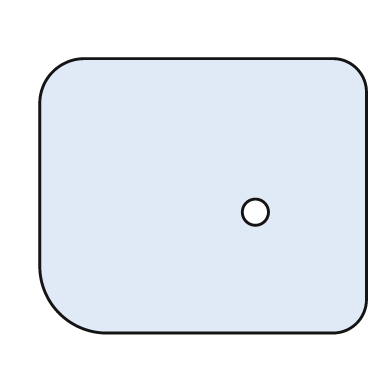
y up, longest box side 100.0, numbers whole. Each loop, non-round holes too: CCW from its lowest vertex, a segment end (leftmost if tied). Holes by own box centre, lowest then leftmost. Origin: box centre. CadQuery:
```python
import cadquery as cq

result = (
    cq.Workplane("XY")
    .moveTo(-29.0, -42.0)
    .lineTo(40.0, -42.0)
    .threePointArc((47.0, -39.0), (50.0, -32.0))
    .lineTo(50.0, 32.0)
    .threePointArc((47.0, 39.0), (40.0, 42.0))
    .lineTo(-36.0, 42.0)
    .threePointArc((-46.0, 38.0), (-50.0, 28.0))
    .lineTo(-50.0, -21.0)
    .threePointArc((-44.0, -36.0), (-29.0, -42.0))
    .close()
    .moveTo(16.0, -5.0)
    .circle(4.0)
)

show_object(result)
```